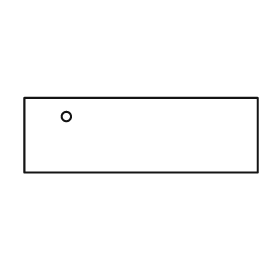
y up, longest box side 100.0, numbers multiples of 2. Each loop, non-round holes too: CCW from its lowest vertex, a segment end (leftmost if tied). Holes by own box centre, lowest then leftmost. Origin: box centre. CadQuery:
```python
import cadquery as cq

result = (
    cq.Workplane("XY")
    .moveTo(-50.0, -16.0)
    .lineTo(50.0, -16.0)
    .lineTo(50.0, 16.0)
    .lineTo(-50.0, 16.0)
    .close()
    .moveTo(-32.0, 8.0)
    .circle(2.0)
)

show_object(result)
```